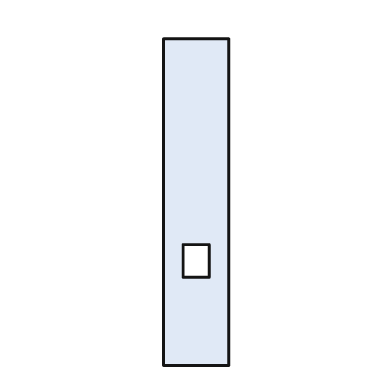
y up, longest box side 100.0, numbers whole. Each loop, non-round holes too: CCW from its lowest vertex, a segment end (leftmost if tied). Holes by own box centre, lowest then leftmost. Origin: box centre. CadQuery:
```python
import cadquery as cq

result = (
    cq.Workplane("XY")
    .moveTo(-10.0, -50.0)
    .lineTo(10.0, -50.0)
    .lineTo(10.0, 50.0)
    .lineTo(-10.0, 50.0)
    .close()
    .moveTo(-4.0, -23.0)
    .lineTo(4.0, -23.0)
    .lineTo(4.0, -13.0)
    .lineTo(-4.0, -13.0)
    .close()
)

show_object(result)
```